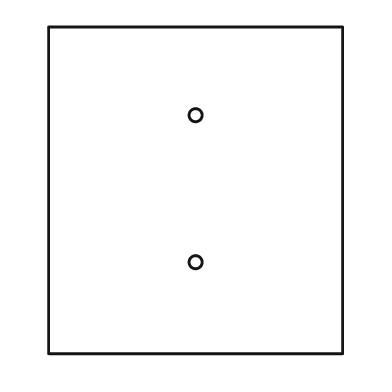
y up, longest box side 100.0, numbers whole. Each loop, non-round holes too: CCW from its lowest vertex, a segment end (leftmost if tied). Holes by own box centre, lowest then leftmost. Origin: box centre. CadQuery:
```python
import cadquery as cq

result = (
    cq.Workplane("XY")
    .moveTo(-45.0, -50.0)
    .lineTo(45.0, -50.0)
    .lineTo(45.0, 50.0)
    .lineTo(-45.0, 50.0)
    .close()
    .moveTo(0.0, -22.0)
    .circle(2.0)
    .moveTo(0.0, 23.0)
    .circle(2.0)
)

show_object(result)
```